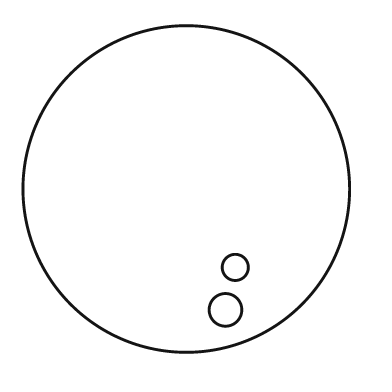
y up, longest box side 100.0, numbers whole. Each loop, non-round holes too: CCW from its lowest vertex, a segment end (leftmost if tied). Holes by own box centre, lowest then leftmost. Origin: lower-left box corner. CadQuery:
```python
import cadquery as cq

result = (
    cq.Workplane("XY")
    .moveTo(50.0, 50.0)
    .circle(50.0)
    .moveTo(62.0, 13.0)
    .circle(5.0)
    .moveTo(65.0, 26.0)
    .circle(4.0)
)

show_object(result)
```